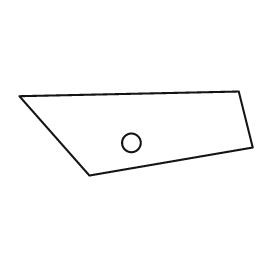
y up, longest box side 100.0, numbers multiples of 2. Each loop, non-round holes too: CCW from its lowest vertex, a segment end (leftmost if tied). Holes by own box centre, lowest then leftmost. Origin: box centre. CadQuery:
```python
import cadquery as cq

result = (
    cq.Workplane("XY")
    .moveTo(-20.0, -18.0)
    .lineTo(50.0, -6.0)
    .lineTo(44.0, 18.0)
    .lineTo(-50.0, 16.0)
    .close()
    .moveTo(-2.0, -4.0)
    .circle(4.0)
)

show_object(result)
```